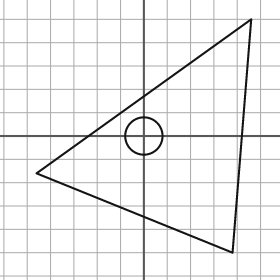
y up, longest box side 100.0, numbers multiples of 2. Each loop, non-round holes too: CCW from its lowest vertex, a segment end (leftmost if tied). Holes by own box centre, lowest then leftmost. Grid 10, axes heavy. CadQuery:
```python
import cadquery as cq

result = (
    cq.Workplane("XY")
    .moveTo(38.0, -50.0)
    .lineTo(46.0, 50.0)
    .lineTo(-46.0, -16.0)
    .close()
    .moveTo(0.0, 0.0)
    .circle(8.0)
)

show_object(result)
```